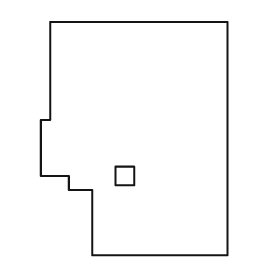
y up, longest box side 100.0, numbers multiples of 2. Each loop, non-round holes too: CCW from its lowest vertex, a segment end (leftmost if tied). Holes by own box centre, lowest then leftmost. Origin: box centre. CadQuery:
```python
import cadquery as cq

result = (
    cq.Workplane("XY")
    .moveTo(-18.0, -50.0)
    .lineTo(40.0, -50.0)
    .lineTo(40.0, 50.0)
    .lineTo(-36.0, 50.0)
    .lineTo(-36.0, 8.0)
    .lineTo(-40.0, 8.0)
    .lineTo(-40.0, -16.0)
    .lineTo(-28.0, -16.0)
    .lineTo(-28.0, -22.0)
    .lineTo(-18.0, -22.0)
    .close()
    .moveTo(-8.0, -20.0)
    .lineTo(0.0, -20.0)
    .lineTo(0.0, -12.0)
    .lineTo(-8.0, -12.0)
    .close()
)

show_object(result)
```